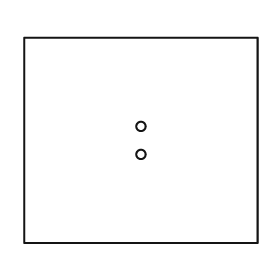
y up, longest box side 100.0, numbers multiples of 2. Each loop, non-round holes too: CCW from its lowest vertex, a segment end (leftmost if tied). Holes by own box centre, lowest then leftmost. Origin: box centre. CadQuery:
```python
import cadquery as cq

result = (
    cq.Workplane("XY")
    .moveTo(-50.0, -44.0)
    .lineTo(50.0, -44.0)
    .lineTo(50.0, 44.0)
    .lineTo(-50.0, 44.0)
    .close()
    .moveTo(0.0, -6.0)
    .circle(2.0)
    .moveTo(0.0, 6.0)
    .circle(2.0)
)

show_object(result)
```